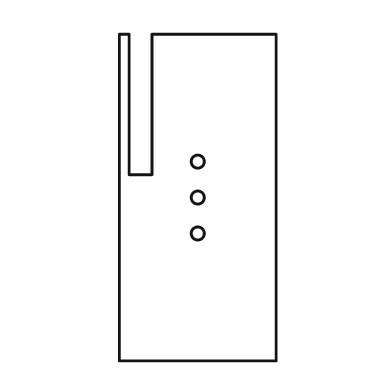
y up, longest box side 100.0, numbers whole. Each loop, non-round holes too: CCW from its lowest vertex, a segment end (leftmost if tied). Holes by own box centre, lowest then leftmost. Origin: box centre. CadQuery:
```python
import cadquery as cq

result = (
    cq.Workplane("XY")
    .moveTo(-24.0, -50.0)
    .lineTo(24.0, -50.0)
    .lineTo(24.0, 50.0)
    .lineTo(-14.0, 50.0)
    .lineTo(-14.0, 7.0)
    .lineTo(-21.0, 7.0)
    .lineTo(-21.0, 50.0)
    .lineTo(-24.0, 50.0)
    .close()
    .moveTo(0.0, -11.0)
    .circle(2.0)
    .moveTo(0.0, 0.0)
    .circle(2.0)
    .moveTo(0.0, 11.0)
    .circle(2.0)
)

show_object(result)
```